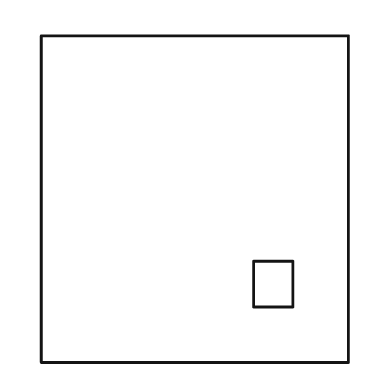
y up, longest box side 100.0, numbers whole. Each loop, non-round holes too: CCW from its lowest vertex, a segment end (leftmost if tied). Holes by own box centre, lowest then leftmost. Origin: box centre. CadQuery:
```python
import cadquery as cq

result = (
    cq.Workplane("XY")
    .moveTo(-47.0, -50.0)
    .lineTo(47.0, -50.0)
    .lineTo(47.0, 50.0)
    .lineTo(-47.0, 50.0)
    .close()
    .moveTo(18.0, -33.0)
    .lineTo(30.0, -33.0)
    .lineTo(30.0, -19.0)
    .lineTo(18.0, -19.0)
    .close()
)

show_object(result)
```